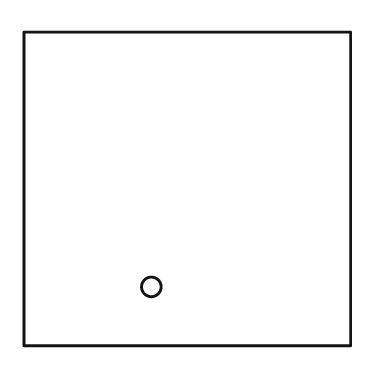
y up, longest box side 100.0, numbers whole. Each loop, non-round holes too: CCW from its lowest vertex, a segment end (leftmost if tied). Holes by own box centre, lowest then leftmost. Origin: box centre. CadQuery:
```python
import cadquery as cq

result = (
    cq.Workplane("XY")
    .moveTo(-50.0, -48.0)
    .lineTo(50.0, -48.0)
    .lineTo(50.0, 48.0)
    .lineTo(-50.0, 48.0)
    .close()
    .moveTo(-11.0, -30.0)
    .circle(3.0)
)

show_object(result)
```